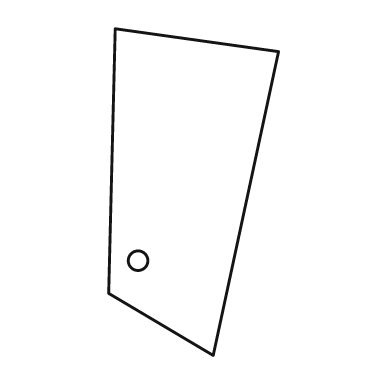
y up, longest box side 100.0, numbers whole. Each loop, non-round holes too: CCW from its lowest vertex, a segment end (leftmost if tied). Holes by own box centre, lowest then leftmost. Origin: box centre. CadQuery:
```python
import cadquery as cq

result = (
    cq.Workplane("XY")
    .moveTo(6.0, -50.0)
    .lineTo(26.0, 43.0)
    .lineTo(-24.0, 50.0)
    .lineTo(-26.0, -31.0)
    .close()
    .moveTo(-17.0, -21.0)
    .circle(3.0)
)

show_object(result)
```